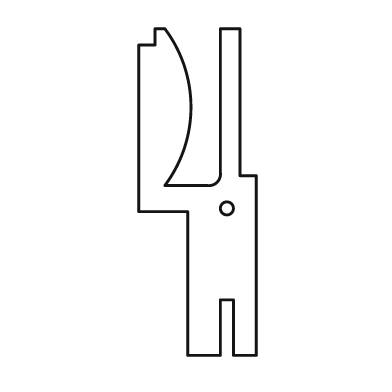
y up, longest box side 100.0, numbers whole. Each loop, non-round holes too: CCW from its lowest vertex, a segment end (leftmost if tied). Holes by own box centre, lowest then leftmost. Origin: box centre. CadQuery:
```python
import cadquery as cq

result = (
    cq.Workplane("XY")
    .moveTo(-3.0, -50.0)
    .lineTo(7.0, -50.0)
    .lineTo(7.0, -33.0)
    .lineTo(11.0, -33.0)
    .lineTo(11.0, -50.0)
    .lineTo(18.0, -50.0)
    .lineTo(18.0, 5.0)
    .lineTo(13.0, 5.0)
    .lineTo(13.0, 50.0)
    .lineTo(7.0, 50.0)
    .lineTo(7.0, 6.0)
    .threePointArc((6.0, 3.0), (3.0, 2.0))
    .lineTo(-10.0, 2.0)
    .threePointArc((-2.0, 26.0), (-10.0, 50.0))
    .lineTo(-13.0, 50.0)
    .lineTo(-13.0, 45.0)
    .lineTo(-18.0, 45.0)
    .lineTo(-18.0, -6.0)
    .lineTo(-3.0, -6.0)
    .close()
    .moveTo(9.0, -5.0)
    .circle(2.0)
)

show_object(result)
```